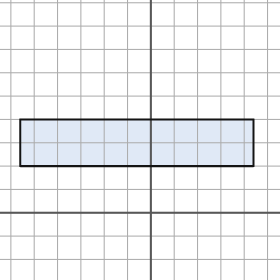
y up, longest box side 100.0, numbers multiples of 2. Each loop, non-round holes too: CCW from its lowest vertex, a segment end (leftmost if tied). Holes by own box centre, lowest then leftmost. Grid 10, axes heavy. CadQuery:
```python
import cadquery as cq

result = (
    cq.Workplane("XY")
    .moveTo(-56.0, 20.0)
    .lineTo(44.0, 20.0)
    .lineTo(44.0, 40.0)
    .lineTo(-56.0, 40.0)
    .close()
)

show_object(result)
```